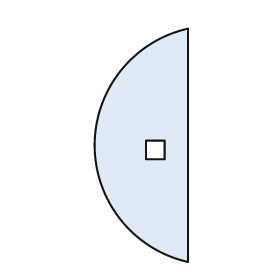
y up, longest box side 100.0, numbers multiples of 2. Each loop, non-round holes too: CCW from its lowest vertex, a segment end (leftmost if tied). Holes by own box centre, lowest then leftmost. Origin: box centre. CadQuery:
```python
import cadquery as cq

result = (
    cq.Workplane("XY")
    .moveTo(20.0, -50.0)
    .lineTo(20.0, 50.0)
    .threePointArc((-20.0, 0.0), (20.0, -50.0))
    .close()
    .moveTo(2.0, -6.0)
    .lineTo(10.0, -6.0)
    .lineTo(10.0, 2.0)
    .lineTo(2.0, 2.0)
    .close()
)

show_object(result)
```